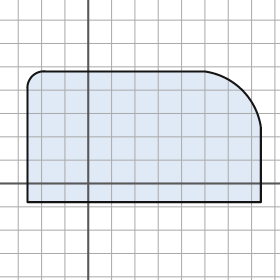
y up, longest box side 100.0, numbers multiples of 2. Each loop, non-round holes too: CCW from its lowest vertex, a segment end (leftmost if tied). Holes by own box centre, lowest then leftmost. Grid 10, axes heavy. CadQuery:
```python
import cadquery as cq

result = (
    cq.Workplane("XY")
    .moveTo(-26.0, -8.0)
    .lineTo(74.0, -8.0)
    .lineTo(74.0, 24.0)
    .threePointArc((66.0, 40.0), (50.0, 48.0))
    .lineTo(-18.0, 48.0)
    .threePointArc((-24.0, 46.0), (-26.0, 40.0))
    .close()
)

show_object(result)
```